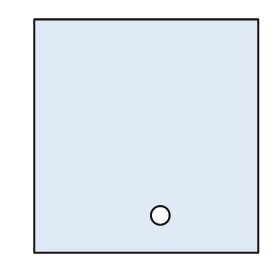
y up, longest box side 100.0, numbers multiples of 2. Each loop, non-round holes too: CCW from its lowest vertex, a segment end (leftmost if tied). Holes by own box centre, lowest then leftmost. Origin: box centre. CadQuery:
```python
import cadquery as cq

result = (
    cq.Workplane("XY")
    .moveTo(-48.0, -50.0)
    .lineTo(48.0, -50.0)
    .lineTo(48.0, 50.0)
    .lineTo(-48.0, 50.0)
    .close()
    .moveTo(6.0, -34.0)
    .circle(4.0)
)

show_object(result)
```